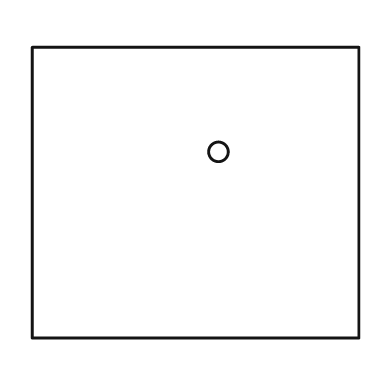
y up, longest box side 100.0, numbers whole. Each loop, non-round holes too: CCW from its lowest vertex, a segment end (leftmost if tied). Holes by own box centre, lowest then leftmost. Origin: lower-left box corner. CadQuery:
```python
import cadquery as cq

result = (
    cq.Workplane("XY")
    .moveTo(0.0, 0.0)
    .lineTo(100.0, 0.0)
    .lineTo(100.0, 89.0)
    .lineTo(0.0, 89.0)
    .close()
    .moveTo(57.0, 57.0)
    .circle(3.0)
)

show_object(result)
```